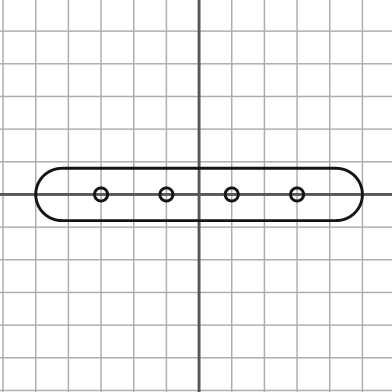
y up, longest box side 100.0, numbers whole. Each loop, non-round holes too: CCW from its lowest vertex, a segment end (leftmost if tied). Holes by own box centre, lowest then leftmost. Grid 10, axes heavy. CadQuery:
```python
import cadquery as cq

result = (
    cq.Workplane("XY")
    .moveTo(-42.0, -8.0)
    .lineTo(42.0, -8.0)
    .threePointArc((50.0, 0.0), (42.0, 8.0))
    .lineTo(-42.0, 8.0)
    .threePointArc((-50.0, 0.0), (-42.0, -8.0))
    .close()
    .moveTo(-30.0, 0.0)
    .circle(2.0)
    .moveTo(-10.0, 0.0)
    .circle(2.0)
    .moveTo(10.0, 0.0)
    .circle(2.0)
    .moveTo(30.0, 0.0)
    .circle(2.0)
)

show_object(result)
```